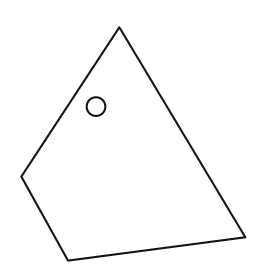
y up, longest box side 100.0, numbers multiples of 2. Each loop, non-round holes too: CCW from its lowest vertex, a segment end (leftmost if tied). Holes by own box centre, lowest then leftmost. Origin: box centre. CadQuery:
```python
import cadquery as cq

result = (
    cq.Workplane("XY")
    .moveTo(-28.0, -50.0)
    .lineTo(48.0, -40.0)
    .lineTo(-6.0, 50.0)
    .lineTo(-48.0, -14.0)
    .close()
    .moveTo(-16.0, 16.0)
    .circle(4.0)
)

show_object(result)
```